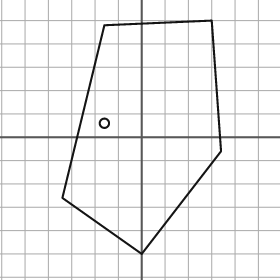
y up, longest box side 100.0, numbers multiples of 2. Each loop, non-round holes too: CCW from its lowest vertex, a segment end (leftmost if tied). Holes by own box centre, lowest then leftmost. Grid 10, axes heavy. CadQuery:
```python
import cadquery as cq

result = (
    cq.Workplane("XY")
    .moveTo(0.0, -50.0)
    .lineTo(34.0, -6.0)
    .lineTo(30.0, 50.0)
    .lineTo(-16.0, 48.0)
    .lineTo(-34.0, -26.0)
    .close()
    .moveTo(-16.0, 6.0)
    .circle(2.0)
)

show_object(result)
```